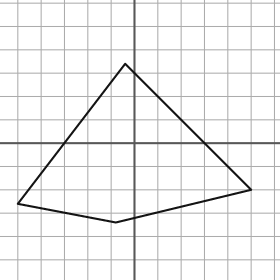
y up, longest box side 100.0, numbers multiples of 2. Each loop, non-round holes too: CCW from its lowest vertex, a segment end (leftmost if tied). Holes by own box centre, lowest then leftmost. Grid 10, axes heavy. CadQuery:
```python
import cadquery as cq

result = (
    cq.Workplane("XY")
    .moveTo(-8.0, -34.0)
    .lineTo(50.0, -20.0)
    .lineTo(-4.0, 34.0)
    .lineTo(-50.0, -26.0)
    .close()
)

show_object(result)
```